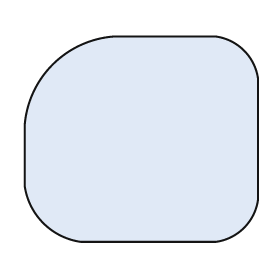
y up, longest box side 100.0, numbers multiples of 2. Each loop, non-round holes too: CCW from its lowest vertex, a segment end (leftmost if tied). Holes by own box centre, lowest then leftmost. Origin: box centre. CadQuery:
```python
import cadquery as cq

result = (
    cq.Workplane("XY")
    .moveTo(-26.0, -44.0)
    .lineTo(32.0, -44.0)
    .threePointArc((44.0, -38.0), (50.0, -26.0))
    .lineTo(50.0, 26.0)
    .threePointArc((44.0, 38.0), (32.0, 44.0))
    .lineTo(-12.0, 44.0)
    .threePointArc((-38.0, 32.0), (-50.0, 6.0))
    .lineTo(-50.0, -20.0)
    .threePointArc((-42.0, -36.0), (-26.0, -44.0))
    .close()
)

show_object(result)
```